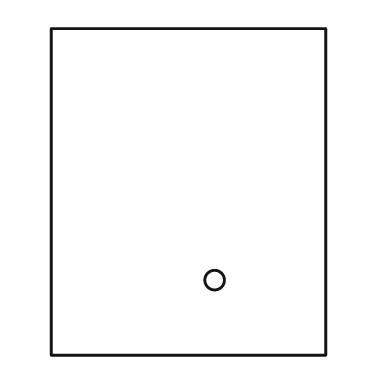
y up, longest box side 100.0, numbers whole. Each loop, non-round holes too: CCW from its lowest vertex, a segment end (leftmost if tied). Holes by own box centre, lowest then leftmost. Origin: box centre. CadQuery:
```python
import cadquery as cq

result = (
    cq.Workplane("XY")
    .moveTo(-42.0, -50.0)
    .lineTo(42.0, -50.0)
    .lineTo(42.0, 50.0)
    .lineTo(-42.0, 50.0)
    .close()
    .moveTo(8.0, -27.0)
    .circle(3.0)
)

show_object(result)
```